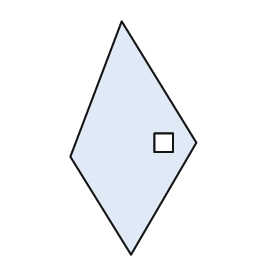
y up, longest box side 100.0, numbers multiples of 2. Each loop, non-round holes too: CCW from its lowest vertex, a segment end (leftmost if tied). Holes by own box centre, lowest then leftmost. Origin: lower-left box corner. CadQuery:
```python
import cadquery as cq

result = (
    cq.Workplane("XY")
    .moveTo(26.0, 0.0)
    .lineTo(54.0, 48.0)
    .lineTo(22.0, 100.0)
    .lineTo(0.0, 42.0)
    .close()
    .moveTo(36.0, 44.0)
    .lineTo(44.0, 44.0)
    .lineTo(44.0, 52.0)
    .lineTo(36.0, 52.0)
    .close()
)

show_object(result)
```